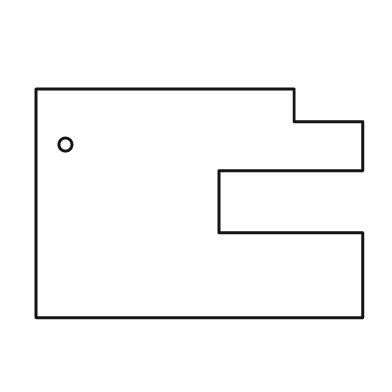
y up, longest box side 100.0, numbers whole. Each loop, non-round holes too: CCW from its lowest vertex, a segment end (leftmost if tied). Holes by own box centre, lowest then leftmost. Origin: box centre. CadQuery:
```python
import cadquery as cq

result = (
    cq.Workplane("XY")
    .moveTo(-50.0, -35.0)
    .lineTo(50.0, -35.0)
    .lineTo(50.0, -9.0)
    .lineTo(6.0, -9.0)
    .lineTo(6.0, 10.0)
    .lineTo(50.0, 10.0)
    .lineTo(50.0, 25.0)
    .lineTo(29.0, 25.0)
    .lineTo(29.0, 35.0)
    .lineTo(-50.0, 35.0)
    .close()
    .moveTo(-41.0, 18.0)
    .circle(2.0)
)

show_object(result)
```